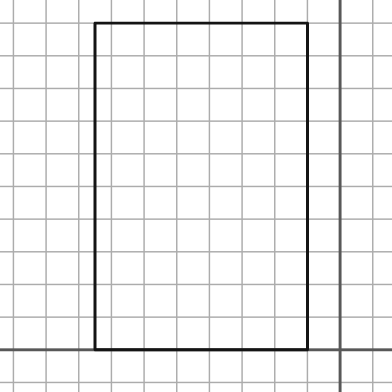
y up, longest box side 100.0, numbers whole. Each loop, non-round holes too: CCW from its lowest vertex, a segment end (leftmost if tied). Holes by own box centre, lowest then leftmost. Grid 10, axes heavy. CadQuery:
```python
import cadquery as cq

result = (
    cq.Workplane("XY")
    .moveTo(-75.0, 0.0)
    .lineTo(-10.0, 0.0)
    .lineTo(-10.0, 100.0)
    .lineTo(-75.0, 100.0)
    .close()
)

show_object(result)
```